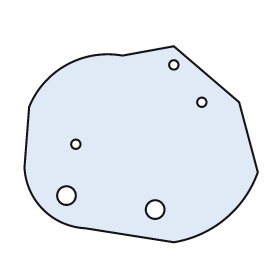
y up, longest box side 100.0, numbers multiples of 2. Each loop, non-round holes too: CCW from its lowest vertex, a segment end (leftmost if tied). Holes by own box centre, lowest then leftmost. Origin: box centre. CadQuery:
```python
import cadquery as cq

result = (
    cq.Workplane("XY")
    .moveTo(14.0, -42.0)
    .threePointArc((36.0, -32.0), (50.0, -12.0))
    .lineTo(42.0, 18.0)
    .lineTo(14.0, 42.0)
    .lineTo(-8.0, 38.0)
    .threePointArc((-32.0, 34.0), (-48.0, 16.0))
    .lineTo(-50.0, -10.0)
    .threePointArc((-42.0, -28.0), (-24.0, -36.0))
    .close()
    .moveTo(6.0, -28.0)
    .circle(4.0)
    .moveTo(-32.0, -22.0)
    .circle(4.0)
    .moveTo(-28.0, 0.0)
    .circle(2.0)
    .moveTo(26.0, 18.0)
    .circle(2.0)
    .moveTo(14.0, 34.0)
    .circle(2.0)
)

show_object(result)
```